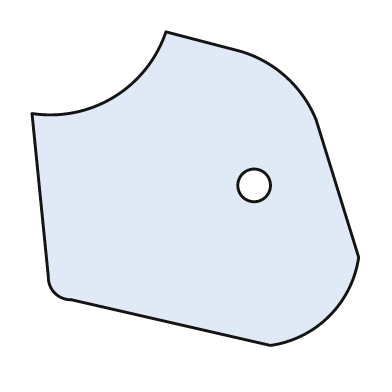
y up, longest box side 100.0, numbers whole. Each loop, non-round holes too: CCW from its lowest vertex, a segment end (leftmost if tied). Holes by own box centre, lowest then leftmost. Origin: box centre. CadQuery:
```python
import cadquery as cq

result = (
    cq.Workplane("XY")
    .moveTo(23.0, -48.0)
    .threePointArc((41.0, -39.0), (50.0, -21.0))
    .lineTo(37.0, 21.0)
    .threePointArc((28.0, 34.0), (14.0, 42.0))
    .lineTo(-9.0, 48.0)
    .threePointArc((-25.0, 28.0), (-50.0, 23.0))
    .lineTo(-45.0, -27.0)
    .threePointArc((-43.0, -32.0), (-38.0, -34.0))
    .close()
    .moveTo(18.0, 1.0)
    .circle(5.0)
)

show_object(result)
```